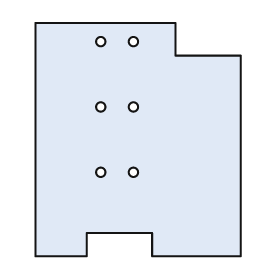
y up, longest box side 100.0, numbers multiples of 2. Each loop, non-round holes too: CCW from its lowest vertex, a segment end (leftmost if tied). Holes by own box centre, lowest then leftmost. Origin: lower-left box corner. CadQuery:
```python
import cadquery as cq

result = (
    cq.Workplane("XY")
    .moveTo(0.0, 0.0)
    .lineTo(22.0, 0.0)
    .lineTo(22.0, 10.0)
    .lineTo(50.0, 10.0)
    .lineTo(50.0, 0.0)
    .lineTo(88.0, 0.0)
    .lineTo(88.0, 86.0)
    .lineTo(60.0, 86.0)
    .lineTo(60.0, 100.0)
    .lineTo(0.0, 100.0)
    .close()
    .moveTo(28.0, 36.0)
    .circle(2.0)
    .moveTo(42.0, 36.0)
    .circle(2.0)
    .moveTo(28.0, 64.0)
    .circle(2.0)
    .moveTo(42.0, 64.0)
    .circle(2.0)
    .moveTo(28.0, 92.0)
    .circle(2.0)
    .moveTo(42.0, 92.0)
    .circle(2.0)
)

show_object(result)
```